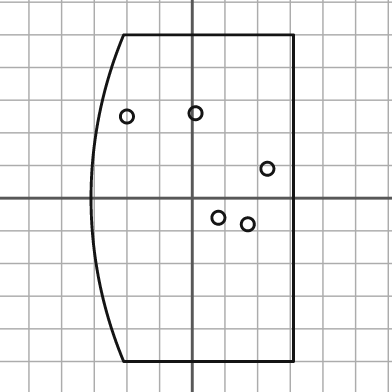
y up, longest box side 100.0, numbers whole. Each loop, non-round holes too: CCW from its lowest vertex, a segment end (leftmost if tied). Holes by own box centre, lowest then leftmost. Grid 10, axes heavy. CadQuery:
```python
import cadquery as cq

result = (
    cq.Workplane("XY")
    .moveTo(-21.0, -50.0)
    .lineTo(31.0, -50.0)
    .lineTo(31.0, 50.0)
    .lineTo(-21.0, 50.0)
    .threePointArc((-31.0, 0.0), (-21.0, -50.0))
    .close()
    .moveTo(17.0, -8.0)
    .circle(2.0)
    .moveTo(8.0, -6.0)
    .circle(2.0)
    .moveTo(23.0, 9.0)
    .circle(2.0)
    .moveTo(-20.0, 25.0)
    .circle(2.0)
    .moveTo(1.0, 26.0)
    .circle(2.0)
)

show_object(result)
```